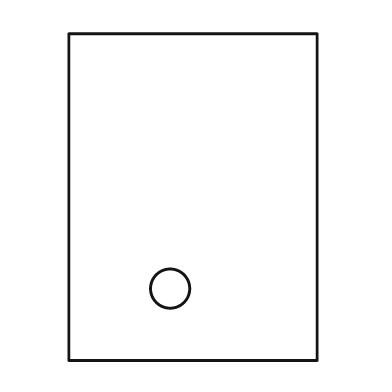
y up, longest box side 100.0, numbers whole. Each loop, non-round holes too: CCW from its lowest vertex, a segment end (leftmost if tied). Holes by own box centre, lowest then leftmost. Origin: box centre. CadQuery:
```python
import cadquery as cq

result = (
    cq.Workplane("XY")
    .moveTo(-38.0, -50.0)
    .lineTo(38.0, -50.0)
    .lineTo(38.0, 50.0)
    .lineTo(-38.0, 50.0)
    .close()
    .moveTo(-7.0, -28.0)
    .circle(6.0)
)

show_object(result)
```